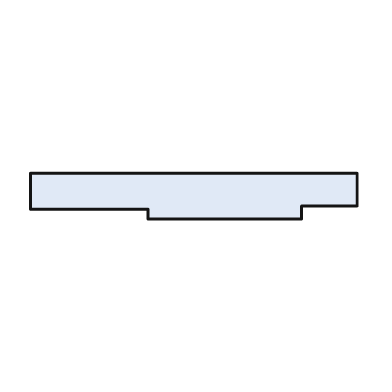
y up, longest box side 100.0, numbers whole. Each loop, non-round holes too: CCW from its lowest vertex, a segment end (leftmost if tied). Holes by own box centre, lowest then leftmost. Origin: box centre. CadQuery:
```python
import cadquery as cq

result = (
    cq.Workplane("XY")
    .moveTo(-14.0, -7.0)
    .lineTo(33.0, -7.0)
    .lineTo(33.0, -3.0)
    .lineTo(50.0, -3.0)
    .lineTo(50.0, 7.0)
    .lineTo(-50.0, 7.0)
    .lineTo(-50.0, -4.0)
    .lineTo(-14.0, -4.0)
    .close()
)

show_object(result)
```